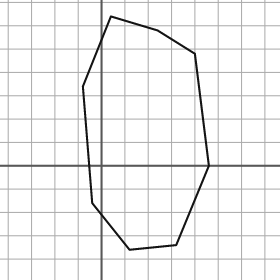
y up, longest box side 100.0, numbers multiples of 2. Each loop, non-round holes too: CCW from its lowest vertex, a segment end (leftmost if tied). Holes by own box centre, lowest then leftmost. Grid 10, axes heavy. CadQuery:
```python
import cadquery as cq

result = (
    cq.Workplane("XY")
    .moveTo(12.0, -36.0)
    .lineTo(32.0, -34.0)
    .lineTo(46.0, 0.0)
    .lineTo(40.0, 48.0)
    .lineTo(24.0, 58.0)
    .lineTo(4.0, 64.0)
    .lineTo(-8.0, 34.0)
    .lineTo(-4.0, -16.0)
    .close()
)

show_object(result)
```